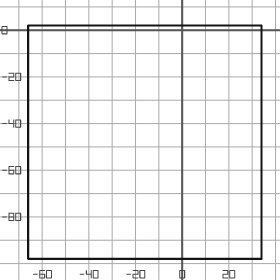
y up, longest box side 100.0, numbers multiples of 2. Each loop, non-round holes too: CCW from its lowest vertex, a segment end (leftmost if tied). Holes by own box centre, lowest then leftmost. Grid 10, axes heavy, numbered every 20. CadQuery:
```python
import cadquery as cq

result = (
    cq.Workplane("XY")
    .moveTo(-66.0, -98.0)
    .lineTo(34.0, -98.0)
    .lineTo(34.0, 2.0)
    .lineTo(-66.0, 2.0)
    .close()
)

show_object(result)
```